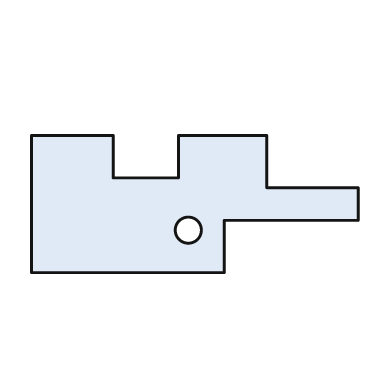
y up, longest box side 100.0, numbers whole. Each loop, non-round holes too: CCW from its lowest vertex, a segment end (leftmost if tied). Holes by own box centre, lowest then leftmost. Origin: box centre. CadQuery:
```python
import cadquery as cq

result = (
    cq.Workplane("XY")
    .moveTo(-50.0, -21.0)
    .lineTo(9.0, -21.0)
    .lineTo(9.0, -5.0)
    .lineTo(50.0, -5.0)
    .lineTo(50.0, 5.0)
    .lineTo(22.0, 5.0)
    .lineTo(22.0, 21.0)
    .lineTo(-5.0, 21.0)
    .lineTo(-5.0, 8.0)
    .lineTo(-25.0, 8.0)
    .lineTo(-25.0, 21.0)
    .lineTo(-50.0, 21.0)
    .close()
    .moveTo(-2.0, -8.0)
    .circle(4.0)
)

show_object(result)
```